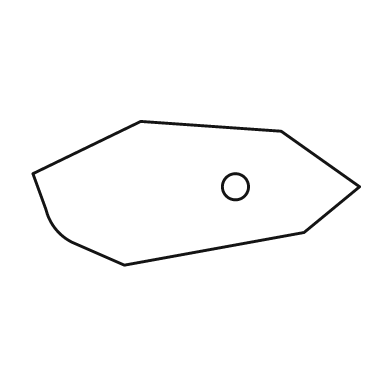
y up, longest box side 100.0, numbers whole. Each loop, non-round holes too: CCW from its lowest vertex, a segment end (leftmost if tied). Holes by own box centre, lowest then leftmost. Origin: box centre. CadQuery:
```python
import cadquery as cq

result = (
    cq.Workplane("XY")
    .moveTo(-22.0, -22.0)
    .lineTo(33.0, -12.0)
    .lineTo(50.0, 2.0)
    .lineTo(26.0, 19.0)
    .lineTo(-17.0, 22.0)
    .lineTo(-50.0, 6.0)
    .lineTo(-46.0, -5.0)
    .threePointArc((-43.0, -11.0), (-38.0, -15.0))
    .close()
    .moveTo(12.0, 2.0)
    .circle(4.0)
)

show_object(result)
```